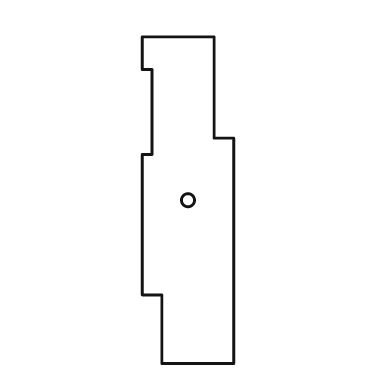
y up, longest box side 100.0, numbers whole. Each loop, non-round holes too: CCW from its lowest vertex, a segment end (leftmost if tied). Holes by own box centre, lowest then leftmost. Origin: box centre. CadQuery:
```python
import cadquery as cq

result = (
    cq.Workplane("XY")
    .moveTo(-8.0, -50.0)
    .lineTo(14.0, -50.0)
    .lineTo(14.0, 19.0)
    .lineTo(8.0, 19.0)
    .lineTo(8.0, 50.0)
    .lineTo(-14.0, 50.0)
    .lineTo(-14.0, 40.0)
    .lineTo(-11.0, 40.0)
    .lineTo(-11.0, 14.0)
    .lineTo(-14.0, 14.0)
    .lineTo(-14.0, -29.0)
    .lineTo(-8.0, -29.0)
    .close()
    .moveTo(0.0, 0.0)
    .circle(2.0)
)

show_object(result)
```